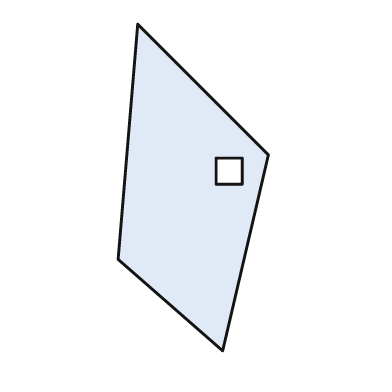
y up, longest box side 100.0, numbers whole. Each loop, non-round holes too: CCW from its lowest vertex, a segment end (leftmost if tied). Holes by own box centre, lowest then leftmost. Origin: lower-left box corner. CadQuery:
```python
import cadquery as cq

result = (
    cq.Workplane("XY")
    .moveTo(32.0, 0.0)
    .lineTo(46.0, 60.0)
    .lineTo(6.0, 100.0)
    .lineTo(0.0, 28.0)
    .close()
    .moveTo(30.0, 51.0)
    .lineTo(38.0, 51.0)
    .lineTo(38.0, 59.0)
    .lineTo(30.0, 59.0)
    .close()
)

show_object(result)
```